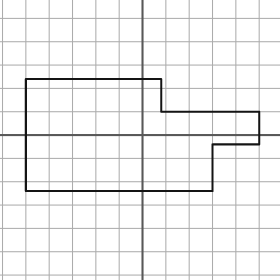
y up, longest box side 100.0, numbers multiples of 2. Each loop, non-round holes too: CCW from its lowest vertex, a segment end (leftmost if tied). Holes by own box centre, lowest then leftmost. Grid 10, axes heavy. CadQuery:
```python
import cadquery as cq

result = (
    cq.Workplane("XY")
    .moveTo(-50.0, -24.0)
    .lineTo(30.0, -24.0)
    .lineTo(30.0, -4.0)
    .lineTo(50.0, -4.0)
    .lineTo(50.0, 10.0)
    .lineTo(8.0, 10.0)
    .lineTo(8.0, 24.0)
    .lineTo(-50.0, 24.0)
    .close()
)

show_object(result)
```